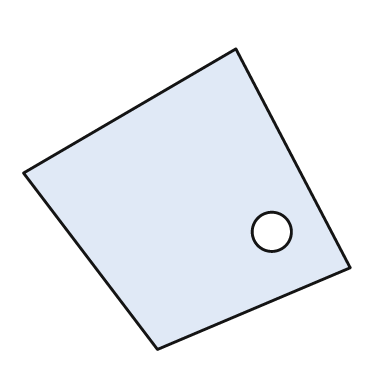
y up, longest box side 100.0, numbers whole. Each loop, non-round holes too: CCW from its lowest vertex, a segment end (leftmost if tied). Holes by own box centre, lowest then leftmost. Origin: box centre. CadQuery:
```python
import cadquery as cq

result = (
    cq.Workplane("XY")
    .moveTo(-9.0, -46.0)
    .lineTo(50.0, -21.0)
    .lineTo(15.0, 46.0)
    .lineTo(-50.0, 8.0)
    .close()
    .moveTo(26.0, -10.0)
    .circle(6.0)
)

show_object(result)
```